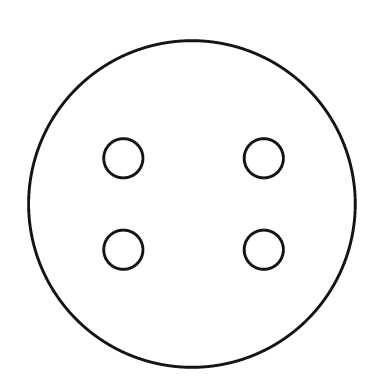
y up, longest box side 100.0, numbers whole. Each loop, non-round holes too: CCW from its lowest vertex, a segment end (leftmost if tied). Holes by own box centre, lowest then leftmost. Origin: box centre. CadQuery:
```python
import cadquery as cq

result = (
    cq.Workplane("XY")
    .moveTo(0.0, 0.0)
    .circle(50.0)
    .moveTo(-21.0, -14.0)
    .circle(6.0)
    .moveTo(22.0, -14.0)
    .circle(6.0)
    .moveTo(-21.0, 14.0)
    .circle(6.0)
    .moveTo(22.0, 14.0)
    .circle(6.0)
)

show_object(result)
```